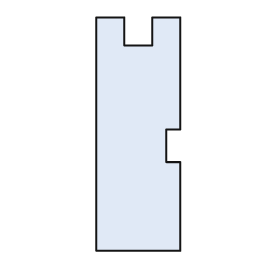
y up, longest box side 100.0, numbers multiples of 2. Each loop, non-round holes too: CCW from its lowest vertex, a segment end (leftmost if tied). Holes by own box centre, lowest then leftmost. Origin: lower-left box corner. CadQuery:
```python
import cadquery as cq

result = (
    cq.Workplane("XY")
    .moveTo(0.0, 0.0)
    .lineTo(36.0, 0.0)
    .lineTo(36.0, 38.0)
    .lineTo(30.0, 38.0)
    .lineTo(30.0, 52.0)
    .lineTo(36.0, 52.0)
    .lineTo(36.0, 100.0)
    .lineTo(24.0, 100.0)
    .lineTo(24.0, 88.0)
    .lineTo(12.0, 88.0)
    .lineTo(12.0, 100.0)
    .lineTo(0.0, 100.0)
    .close()
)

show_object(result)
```